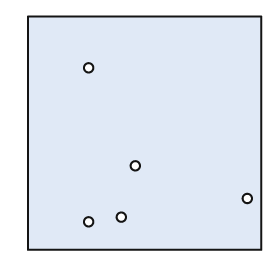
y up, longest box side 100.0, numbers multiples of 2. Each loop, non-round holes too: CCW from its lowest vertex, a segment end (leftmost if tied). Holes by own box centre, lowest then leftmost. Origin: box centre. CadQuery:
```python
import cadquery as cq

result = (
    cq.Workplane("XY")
    .moveTo(-50.0, -50.0)
    .lineTo(50.0, -50.0)
    .lineTo(50.0, 50.0)
    .lineTo(-50.0, 50.0)
    .close()
    .moveTo(-24.0, -38.0)
    .circle(2.0)
    .moveTo(-10.0, -36.0)
    .circle(2.0)
    .moveTo(44.0, -28.0)
    .circle(2.0)
    .moveTo(-4.0, -14.0)
    .circle(2.0)
    .moveTo(-24.0, 28.0)
    .circle(2.0)
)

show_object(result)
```